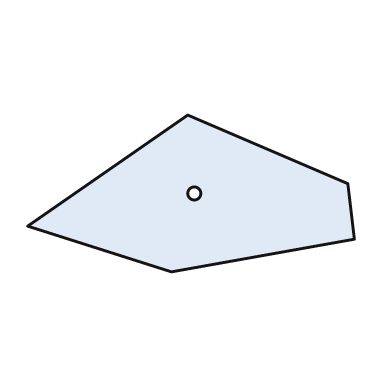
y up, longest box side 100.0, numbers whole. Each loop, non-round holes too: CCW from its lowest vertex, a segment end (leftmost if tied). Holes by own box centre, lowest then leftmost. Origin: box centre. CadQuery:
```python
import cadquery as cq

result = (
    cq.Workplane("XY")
    .moveTo(-6.0, -24.0)
    .lineTo(50.0, -14.0)
    .lineTo(48.0, 3.0)
    .lineTo(-1.0, 24.0)
    .lineTo(-50.0, -10.0)
    .close()
    .moveTo(1.0, 0.0)
    .circle(2.0)
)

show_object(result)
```